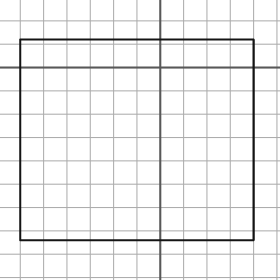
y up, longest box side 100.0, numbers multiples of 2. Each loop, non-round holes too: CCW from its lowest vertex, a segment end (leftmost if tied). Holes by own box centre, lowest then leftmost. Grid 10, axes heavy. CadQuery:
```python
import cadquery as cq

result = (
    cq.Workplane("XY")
    .moveTo(-60.0, -74.0)
    .lineTo(40.0, -74.0)
    .lineTo(40.0, 12.0)
    .lineTo(-60.0, 12.0)
    .close()
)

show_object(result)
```